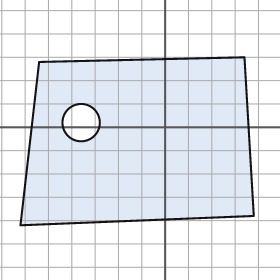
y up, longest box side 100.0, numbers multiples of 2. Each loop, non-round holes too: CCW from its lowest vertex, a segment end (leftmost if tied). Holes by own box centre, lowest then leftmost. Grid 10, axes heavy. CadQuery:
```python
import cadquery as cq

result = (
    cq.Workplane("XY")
    .moveTo(-62.0, -42.0)
    .lineTo(38.0, -38.0)
    .lineTo(34.0, 30.0)
    .lineTo(-54.0, 28.0)
    .close()
    .moveTo(-36.0, 2.0)
    .circle(8.0)
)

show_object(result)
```